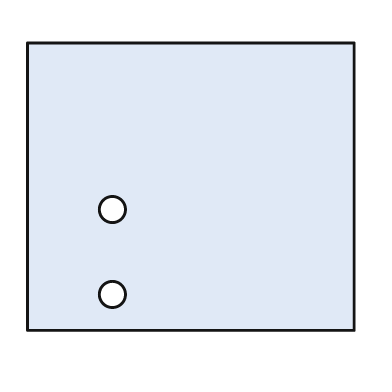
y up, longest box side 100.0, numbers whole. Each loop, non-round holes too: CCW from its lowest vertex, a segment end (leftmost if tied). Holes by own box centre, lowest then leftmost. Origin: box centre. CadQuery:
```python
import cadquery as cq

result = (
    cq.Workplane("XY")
    .moveTo(-50.0, -44.0)
    .lineTo(50.0, -44.0)
    .lineTo(50.0, 44.0)
    .lineTo(-50.0, 44.0)
    .close()
    .moveTo(-24.0, -33.0)
    .circle(4.0)
    .moveTo(-24.0, -7.0)
    .circle(4.0)
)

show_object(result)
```